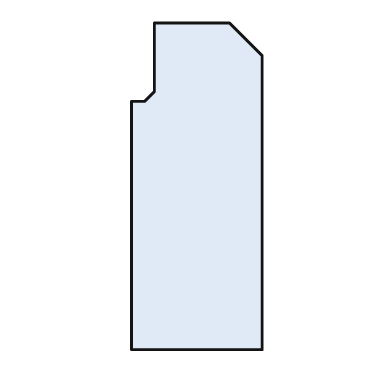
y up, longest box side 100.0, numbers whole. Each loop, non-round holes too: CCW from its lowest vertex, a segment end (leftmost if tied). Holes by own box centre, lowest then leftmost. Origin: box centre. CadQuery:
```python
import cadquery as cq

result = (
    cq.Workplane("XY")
    .moveTo(-20.0, -50.0)
    .lineTo(20.0, -50.0)
    .lineTo(20.0, 40.0)
    .lineTo(10.0, 50.0)
    .lineTo(-13.0, 50.0)
    .lineTo(-13.0, 29.0)
    .lineTo(-16.0, 26.0)
    .lineTo(-20.0, 26.0)
    .close()
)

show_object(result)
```